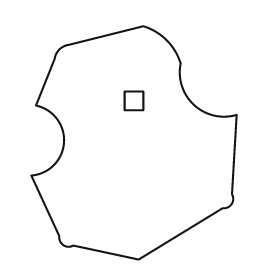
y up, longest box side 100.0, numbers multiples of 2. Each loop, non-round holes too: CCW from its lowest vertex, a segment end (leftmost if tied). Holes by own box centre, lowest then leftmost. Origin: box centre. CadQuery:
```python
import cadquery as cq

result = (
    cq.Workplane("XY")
    .moveTo(2.0, -50.0)
    .lineTo(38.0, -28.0)
    .threePointArc((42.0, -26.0), (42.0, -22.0))
    .lineTo(44.0, 12.0)
    .threePointArc((26.0, 16.0), (20.0, 34.0))
    .threePointArc((14.0, 44.0), (4.0, 50.0))
    .lineTo(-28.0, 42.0)
    .threePointArc((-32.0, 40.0), (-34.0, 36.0))
    .lineTo(-42.0, 16.0)
    .threePointArc((-30.0, 0.0), (-44.0, -14.0))
    .lineTo(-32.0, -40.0)
    .threePointArc((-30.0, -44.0), (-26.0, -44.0))
    .close()
    .moveTo(-4.0, 14.0)
    .lineTo(4.0, 14.0)
    .lineTo(4.0, 22.0)
    .lineTo(-4.0, 22.0)
    .close()
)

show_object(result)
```